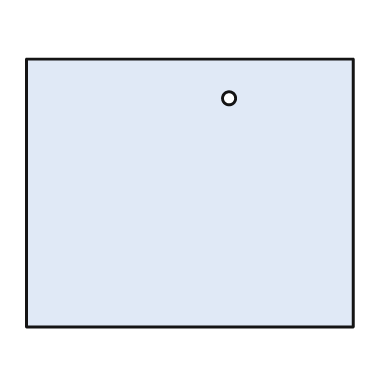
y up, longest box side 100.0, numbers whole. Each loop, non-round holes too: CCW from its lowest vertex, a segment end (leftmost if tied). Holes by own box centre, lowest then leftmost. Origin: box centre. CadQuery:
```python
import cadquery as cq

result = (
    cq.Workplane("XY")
    .moveTo(-50.0, -41.0)
    .lineTo(50.0, -41.0)
    .lineTo(50.0, 41.0)
    .lineTo(-50.0, 41.0)
    .close()
    .moveTo(12.0, 29.0)
    .circle(2.0)
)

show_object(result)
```